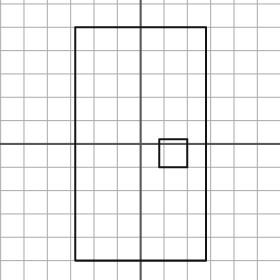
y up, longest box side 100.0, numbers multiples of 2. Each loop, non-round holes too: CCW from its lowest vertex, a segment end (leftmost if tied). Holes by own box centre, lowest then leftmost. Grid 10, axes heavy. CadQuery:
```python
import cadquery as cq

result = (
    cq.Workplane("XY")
    .moveTo(-28.0, -50.0)
    .lineTo(28.0, -50.0)
    .lineTo(28.0, 50.0)
    .lineTo(-28.0, 50.0)
    .close()
    .moveTo(8.0, -10.0)
    .lineTo(20.0, -10.0)
    .lineTo(20.0, 2.0)
    .lineTo(8.0, 2.0)
    .close()
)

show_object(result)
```